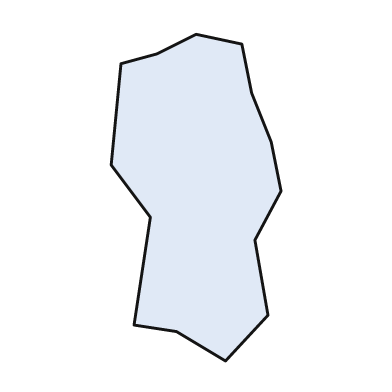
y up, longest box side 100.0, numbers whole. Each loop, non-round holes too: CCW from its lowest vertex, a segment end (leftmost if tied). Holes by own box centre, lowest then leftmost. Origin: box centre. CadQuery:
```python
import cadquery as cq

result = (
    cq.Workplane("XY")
    .moveTo(9.0, -50.0)
    .lineTo(22.0, -36.0)
    .lineTo(18.0, -13.0)
    .lineTo(26.0, 2.0)
    .lineTo(23.0, 17.0)
    .lineTo(17.0, 32.0)
    .lineTo(14.0, 47.0)
    .lineTo(0.0, 50.0)
    .lineTo(-12.0, 44.0)
    .lineTo(-23.0, 41.0)
    .lineTo(-26.0, 10.0)
    .lineTo(-14.0, -6.0)
    .lineTo(-19.0, -39.0)
    .lineTo(-6.0, -41.0)
    .close()
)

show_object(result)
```